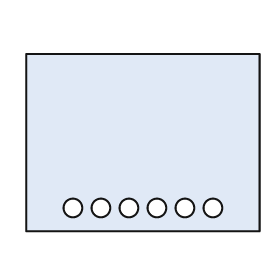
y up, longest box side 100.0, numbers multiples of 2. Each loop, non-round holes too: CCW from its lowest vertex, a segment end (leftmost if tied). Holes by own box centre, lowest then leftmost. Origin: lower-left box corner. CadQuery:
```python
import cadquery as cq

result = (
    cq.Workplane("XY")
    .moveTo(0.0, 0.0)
    .lineTo(100.0, 0.0)
    .lineTo(100.0, 76.0)
    .lineTo(0.0, 76.0)
    .close()
    .moveTo(20.0, 10.0)
    .circle(4.0)
    .moveTo(32.0, 10.0)
    .circle(4.0)
    .moveTo(44.0, 10.0)
    .circle(4.0)
    .moveTo(56.0, 10.0)
    .circle(4.0)
    .moveTo(68.0, 10.0)
    .circle(4.0)
    .moveTo(80.0, 10.0)
    .circle(4.0)
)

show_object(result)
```